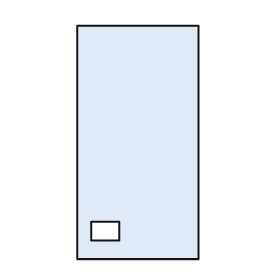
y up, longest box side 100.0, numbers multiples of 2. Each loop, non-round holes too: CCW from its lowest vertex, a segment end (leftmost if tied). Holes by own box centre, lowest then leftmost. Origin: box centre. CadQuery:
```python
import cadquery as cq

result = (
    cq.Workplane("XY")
    .moveTo(-26.0, -50.0)
    .lineTo(26.0, -50.0)
    .lineTo(26.0, 50.0)
    .lineTo(-26.0, 50.0)
    .close()
    .moveTo(-20.0, -42.0)
    .lineTo(-8.0, -42.0)
    .lineTo(-8.0, -34.0)
    .lineTo(-20.0, -34.0)
    .close()
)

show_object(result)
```